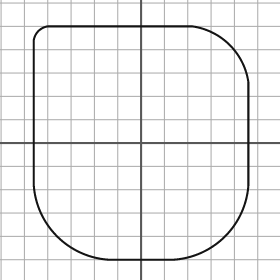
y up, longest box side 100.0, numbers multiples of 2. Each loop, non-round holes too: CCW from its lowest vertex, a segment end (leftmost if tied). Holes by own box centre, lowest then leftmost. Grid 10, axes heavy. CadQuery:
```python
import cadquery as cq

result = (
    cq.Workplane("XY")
    .moveTo(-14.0, -50.0)
    .lineTo(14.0, -50.0)
    .threePointArc((36.0, -40.0), (46.0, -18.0))
    .lineTo(46.0, 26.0)
    .threePointArc((38.0, 42.0), (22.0, 50.0))
    .lineTo(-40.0, 50.0)
    .threePointArc((-44.0, 48.0), (-46.0, 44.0))
    .lineTo(-46.0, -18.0)
    .threePointArc((-36.0, -40.0), (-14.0, -50.0))
    .close()
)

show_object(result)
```